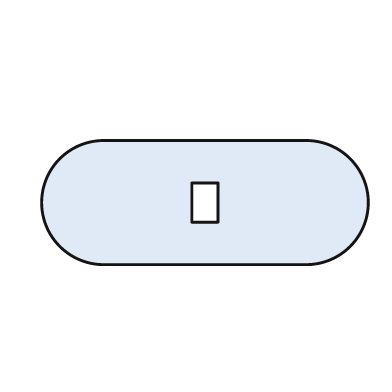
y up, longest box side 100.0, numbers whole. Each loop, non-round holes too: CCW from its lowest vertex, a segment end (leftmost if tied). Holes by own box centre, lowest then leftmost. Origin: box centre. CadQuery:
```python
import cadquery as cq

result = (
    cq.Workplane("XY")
    .moveTo(-31.0, -19.0)
    .lineTo(31.0, -19.0)
    .threePointArc((50.0, 0.0), (31.0, 19.0))
    .lineTo(-31.0, 19.0)
    .threePointArc((-50.0, 0.0), (-31.0, -19.0))
    .close()
    .moveTo(-4.0, -6.0)
    .lineTo(4.0, -6.0)
    .lineTo(4.0, 6.0)
    .lineTo(-4.0, 6.0)
    .close()
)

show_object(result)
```